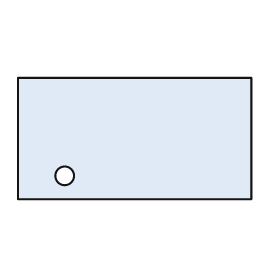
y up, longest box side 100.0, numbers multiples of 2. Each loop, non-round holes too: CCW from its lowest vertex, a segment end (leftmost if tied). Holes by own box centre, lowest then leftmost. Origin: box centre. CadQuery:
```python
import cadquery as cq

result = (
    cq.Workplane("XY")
    .moveTo(-50.0, -26.0)
    .lineTo(50.0, -26.0)
    .lineTo(50.0, 26.0)
    .lineTo(-50.0, 26.0)
    .close()
    .moveTo(-30.0, -16.0)
    .circle(4.0)
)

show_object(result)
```